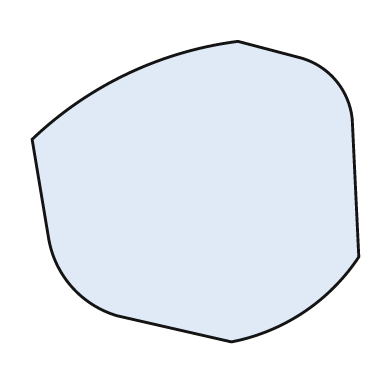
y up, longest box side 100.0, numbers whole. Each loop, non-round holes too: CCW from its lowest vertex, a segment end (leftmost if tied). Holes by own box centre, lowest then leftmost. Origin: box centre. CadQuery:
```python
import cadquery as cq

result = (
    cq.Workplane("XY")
    .moveTo(11.0, -46.0)
    .threePointArc((33.0, -37.0), (50.0, -20.0))
    .lineTo(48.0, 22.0)
    .threePointArc((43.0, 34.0), (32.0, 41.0))
    .lineTo(13.0, 46.0)
    .threePointArc((-21.0, 36.0), (-50.0, 16.0))
    .lineTo(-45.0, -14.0)
    .threePointArc((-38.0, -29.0), (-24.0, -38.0))
    .close()
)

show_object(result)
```